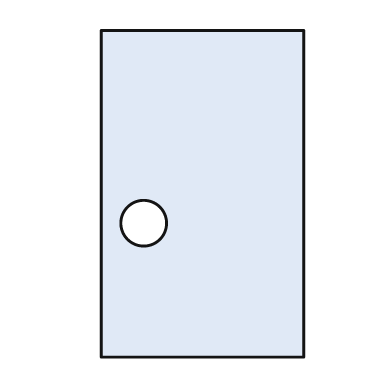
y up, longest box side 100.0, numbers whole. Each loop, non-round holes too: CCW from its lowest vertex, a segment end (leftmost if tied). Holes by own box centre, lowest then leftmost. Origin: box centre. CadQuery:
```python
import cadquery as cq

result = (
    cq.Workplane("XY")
    .moveTo(-31.0, -50.0)
    .lineTo(31.0, -50.0)
    .lineTo(31.0, 50.0)
    .lineTo(-31.0, 50.0)
    .close()
    .moveTo(-18.0, -9.0)
    .circle(7.0)
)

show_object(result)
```